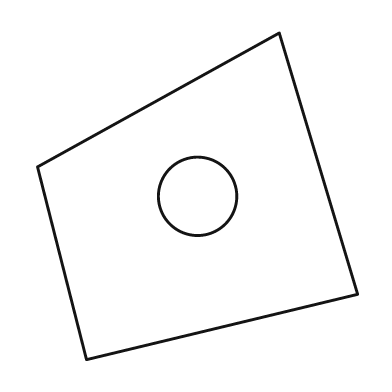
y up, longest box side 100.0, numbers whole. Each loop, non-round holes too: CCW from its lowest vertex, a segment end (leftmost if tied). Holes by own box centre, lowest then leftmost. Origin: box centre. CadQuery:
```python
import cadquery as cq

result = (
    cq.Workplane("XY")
    .moveTo(-34.0, -50.0)
    .lineTo(49.0, -30.0)
    .lineTo(25.0, 50.0)
    .lineTo(-49.0, 9.0)
    .close()
    .moveTo(0.0, 0.0)
    .circle(12.0)
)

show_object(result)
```